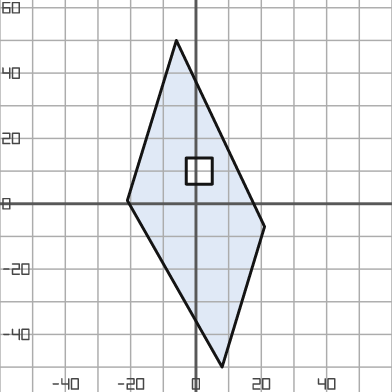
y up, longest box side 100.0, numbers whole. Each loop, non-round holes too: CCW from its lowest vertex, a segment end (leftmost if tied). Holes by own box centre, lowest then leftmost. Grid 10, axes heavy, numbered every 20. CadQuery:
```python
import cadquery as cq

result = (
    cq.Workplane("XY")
    .moveTo(8.0, -50.0)
    .lineTo(21.0, -7.0)
    .lineTo(-6.0, 50.0)
    .lineTo(-21.0, 1.0)
    .close()
    .moveTo(-3.0, 6.0)
    .lineTo(5.0, 6.0)
    .lineTo(5.0, 14.0)
    .lineTo(-3.0, 14.0)
    .close()
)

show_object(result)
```